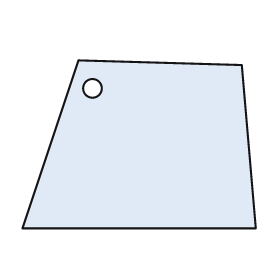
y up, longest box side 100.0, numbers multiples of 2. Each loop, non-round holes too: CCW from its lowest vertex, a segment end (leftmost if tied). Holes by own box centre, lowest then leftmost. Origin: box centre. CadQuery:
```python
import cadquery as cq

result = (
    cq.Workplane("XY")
    .moveTo(-50.0, -36.0)
    .lineTo(50.0, -36.0)
    .lineTo(44.0, 34.0)
    .lineTo(-26.0, 36.0)
    .close()
    .moveTo(-20.0, 24.0)
    .circle(4.0)
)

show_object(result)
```